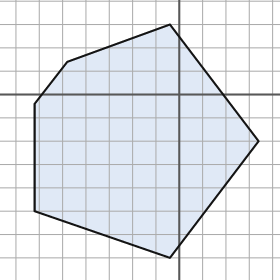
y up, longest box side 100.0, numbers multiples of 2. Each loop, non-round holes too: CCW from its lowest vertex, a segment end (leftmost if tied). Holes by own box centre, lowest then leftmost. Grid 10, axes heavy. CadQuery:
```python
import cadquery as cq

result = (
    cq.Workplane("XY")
    .moveTo(-4.0, -70.0)
    .lineTo(34.0, -20.0)
    .lineTo(-4.0, 30.0)
    .lineTo(-48.0, 14.0)
    .lineTo(-62.0, -4.0)
    .lineTo(-62.0, -50.0)
    .close()
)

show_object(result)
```